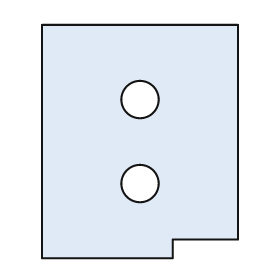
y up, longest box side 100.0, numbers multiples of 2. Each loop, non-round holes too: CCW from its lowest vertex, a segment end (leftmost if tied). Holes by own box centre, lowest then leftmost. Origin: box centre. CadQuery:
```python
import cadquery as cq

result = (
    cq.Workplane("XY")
    .moveTo(-42.0, -50.0)
    .lineTo(14.0, -50.0)
    .lineTo(14.0, -42.0)
    .lineTo(42.0, -42.0)
    .lineTo(42.0, 50.0)
    .lineTo(-42.0, 50.0)
    .close()
    .moveTo(0.0, -18.0)
    .circle(8.0)
    .moveTo(0.0, 18.0)
    .circle(8.0)
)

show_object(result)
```